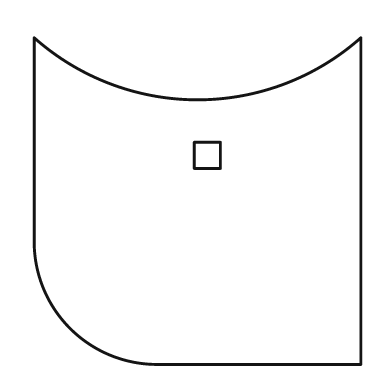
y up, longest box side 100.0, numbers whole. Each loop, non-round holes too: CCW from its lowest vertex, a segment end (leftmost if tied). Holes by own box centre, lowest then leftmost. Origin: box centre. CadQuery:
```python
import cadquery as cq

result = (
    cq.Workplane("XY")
    .moveTo(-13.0, -50.0)
    .lineTo(50.0, -50.0)
    .lineTo(50.0, 50.0)
    .threePointArc((0.0, 31.0), (-50.0, 50.0))
    .lineTo(-50.0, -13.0)
    .threePointArc((-39.0, -39.0), (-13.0, -50.0))
    .close()
    .moveTo(-1.0, 10.0)
    .lineTo(7.0, 10.0)
    .lineTo(7.0, 18.0)
    .lineTo(-1.0, 18.0)
    .close()
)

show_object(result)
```